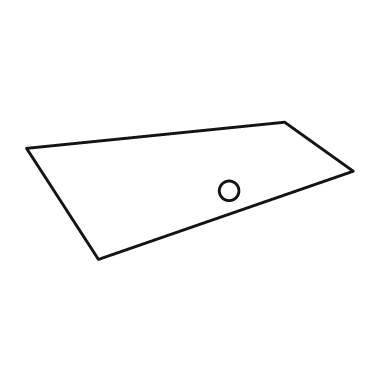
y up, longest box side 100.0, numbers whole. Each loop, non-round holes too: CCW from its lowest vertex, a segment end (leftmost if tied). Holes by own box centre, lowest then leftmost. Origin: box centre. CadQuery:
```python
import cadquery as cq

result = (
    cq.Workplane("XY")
    .moveTo(-28.0, -21.0)
    .lineTo(50.0, 6.0)
    .lineTo(29.0, 21.0)
    .lineTo(-50.0, 13.0)
    .close()
    .moveTo(12.0, 0.0)
    .circle(3.0)
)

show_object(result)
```